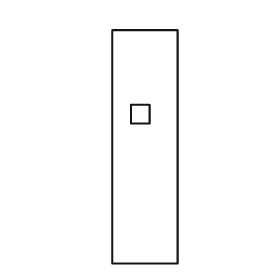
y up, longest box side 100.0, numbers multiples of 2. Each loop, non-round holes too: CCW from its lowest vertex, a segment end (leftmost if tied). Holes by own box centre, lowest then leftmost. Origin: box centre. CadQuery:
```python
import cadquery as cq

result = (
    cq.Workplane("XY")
    .moveTo(-14.0, -50.0)
    .lineTo(14.0, -50.0)
    .lineTo(14.0, 50.0)
    .lineTo(-14.0, 50.0)
    .close()
    .moveTo(-6.0, 10.0)
    .lineTo(2.0, 10.0)
    .lineTo(2.0, 18.0)
    .lineTo(-6.0, 18.0)
    .close()
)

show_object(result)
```